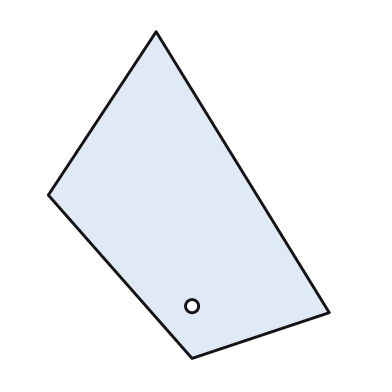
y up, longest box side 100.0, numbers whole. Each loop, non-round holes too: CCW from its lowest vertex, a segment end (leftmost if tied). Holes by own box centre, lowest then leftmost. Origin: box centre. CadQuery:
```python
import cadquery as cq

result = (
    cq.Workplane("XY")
    .moveTo(1.0, -50.0)
    .lineTo(43.0, -36.0)
    .lineTo(-10.0, 50.0)
    .lineTo(-43.0, 0.0)
    .close()
    .moveTo(1.0, -34.0)
    .circle(2.0)
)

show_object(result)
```